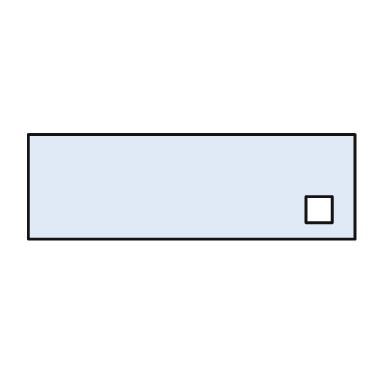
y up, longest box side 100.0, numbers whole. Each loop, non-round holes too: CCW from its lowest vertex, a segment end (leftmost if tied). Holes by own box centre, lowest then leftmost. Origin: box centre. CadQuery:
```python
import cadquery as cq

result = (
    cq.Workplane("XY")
    .moveTo(-50.0, -16.0)
    .lineTo(50.0, -16.0)
    .lineTo(50.0, 16.0)
    .lineTo(-50.0, 16.0)
    .close()
    .moveTo(35.0, -11.0)
    .lineTo(43.0, -11.0)
    .lineTo(43.0, -3.0)
    .lineTo(35.0, -3.0)
    .close()
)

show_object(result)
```